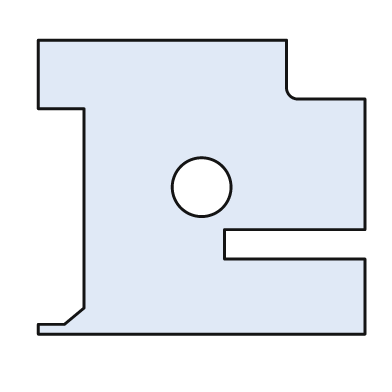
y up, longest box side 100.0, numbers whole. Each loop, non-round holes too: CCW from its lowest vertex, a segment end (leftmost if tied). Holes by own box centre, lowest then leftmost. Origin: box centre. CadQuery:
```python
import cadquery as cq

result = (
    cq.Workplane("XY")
    .moveTo(-50.0, -45.0)
    .lineTo(50.0, -45.0)
    .lineTo(50.0, -22.0)
    .lineTo(7.0, -22.0)
    .lineTo(7.0, -13.0)
    .lineTo(50.0, -13.0)
    .lineTo(50.0, 27.0)
    .lineTo(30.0, 27.0)
    .threePointArc((27.0, 28.0), (26.0, 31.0))
    .lineTo(26.0, 45.0)
    .lineTo(-50.0, 45.0)
    .lineTo(-50.0, 24.0)
    .lineTo(-36.0, 24.0)
    .lineTo(-36.0, -37.0)
    .lineTo(-42.0, -42.0)
    .lineTo(-50.0, -42.0)
    .close()
    .moveTo(0.0, 0.0)
    .circle(9.0)
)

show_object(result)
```